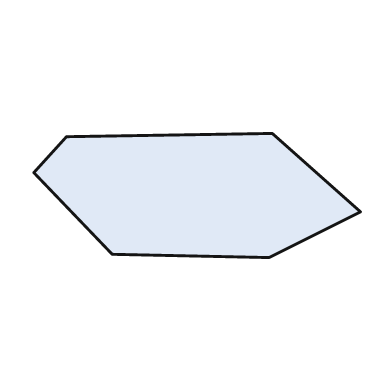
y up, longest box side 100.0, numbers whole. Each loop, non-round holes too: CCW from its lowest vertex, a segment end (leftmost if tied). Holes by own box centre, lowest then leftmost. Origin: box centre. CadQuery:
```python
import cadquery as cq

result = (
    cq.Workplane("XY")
    .moveTo(22.0, -19.0)
    .lineTo(50.0, -5.0)
    .lineTo(23.0, 19.0)
    .lineTo(-40.0, 18.0)
    .lineTo(-50.0, 7.0)
    .lineTo(-26.0, -18.0)
    .close()
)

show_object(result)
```